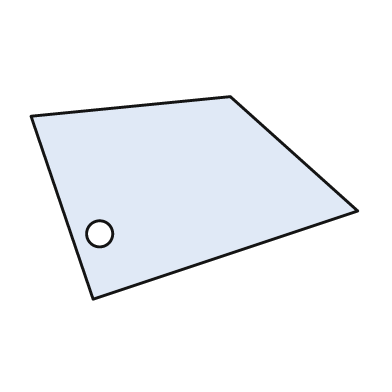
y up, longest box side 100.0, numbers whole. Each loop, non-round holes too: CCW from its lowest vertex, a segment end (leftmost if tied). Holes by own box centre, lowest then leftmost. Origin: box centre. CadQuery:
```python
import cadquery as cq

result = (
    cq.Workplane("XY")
    .moveTo(-31.0, -31.0)
    .lineTo(50.0, -4.0)
    .lineTo(11.0, 31.0)
    .lineTo(-50.0, 25.0)
    .close()
    .moveTo(-29.0, -11.0)
    .circle(4.0)
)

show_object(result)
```